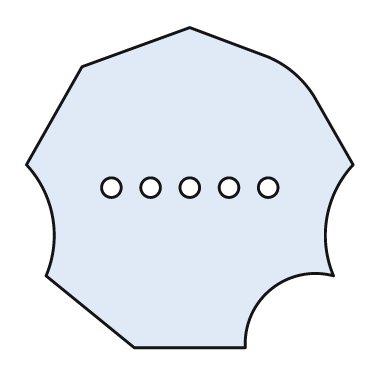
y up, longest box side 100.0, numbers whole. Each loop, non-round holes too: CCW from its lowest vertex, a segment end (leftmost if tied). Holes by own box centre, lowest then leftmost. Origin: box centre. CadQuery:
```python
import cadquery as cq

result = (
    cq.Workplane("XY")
    .moveTo(-17.0, -49.0)
    .lineTo(17.0, -49.0)
    .threePointArc((25.0, -31.0), (44.0, -27.0))
    .threePointArc((42.0, -9.0), (50.0, 7.0))
    .lineTo(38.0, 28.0)
    .threePointArc((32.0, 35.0), (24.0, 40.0))
    .lineTo(0.0, 49.0)
    .lineTo(-33.0, 37.0)
    .lineTo(-50.0, 7.0)
    .threePointArc((-42.0, -9.0), (-44.0, -27.0))
    .close()
    .moveTo(-24.0, 0.0)
    .circle(3.0)
    .moveTo(-12.0, 0.0)
    .circle(3.0)
    .moveTo(0.0, 0.0)
    .circle(3.0)
    .moveTo(12.0, 0.0)
    .circle(3.0)
    .moveTo(24.0, 0.0)
    .circle(3.0)
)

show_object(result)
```